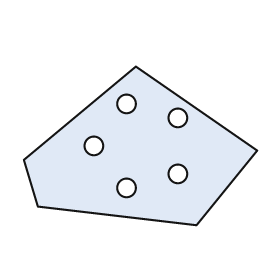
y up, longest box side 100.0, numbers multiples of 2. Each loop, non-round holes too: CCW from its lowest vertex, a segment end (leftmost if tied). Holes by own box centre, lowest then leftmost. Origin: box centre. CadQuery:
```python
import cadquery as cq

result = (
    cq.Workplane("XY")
    .moveTo(24.0, -34.0)
    .lineTo(50.0, -2.0)
    .lineTo(-2.0, 34.0)
    .lineTo(-50.0, -6.0)
    .lineTo(-44.0, -26.0)
    .close()
    .moveTo(-6.0, -18.0)
    .circle(4.0)
    .moveTo(16.0, -12.0)
    .circle(4.0)
    .moveTo(-20.0, 0.0)
    .circle(4.0)
    .moveTo(16.0, 12.0)
    .circle(4.0)
    .moveTo(-6.0, 18.0)
    .circle(4.0)
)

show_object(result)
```